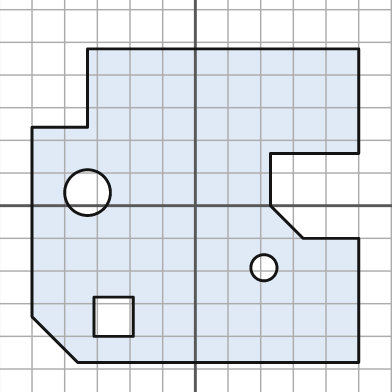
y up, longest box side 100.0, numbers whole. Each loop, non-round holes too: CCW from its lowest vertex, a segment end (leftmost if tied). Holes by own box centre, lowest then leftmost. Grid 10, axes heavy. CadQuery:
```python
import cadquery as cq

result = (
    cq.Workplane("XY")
    .moveTo(-36.0, -48.0)
    .lineTo(50.0, -48.0)
    .lineTo(50.0, -10.0)
    .lineTo(33.0, -10.0)
    .lineTo(23.0, 0.0)
    .lineTo(23.0, 16.0)
    .lineTo(50.0, 16.0)
    .lineTo(50.0, 48.0)
    .lineTo(-33.0, 48.0)
    .lineTo(-33.0, 24.0)
    .lineTo(-50.0, 24.0)
    .lineTo(-50.0, -34.0)
    .close()
    .moveTo(-31.0, -40.0)
    .lineTo(-19.0, -40.0)
    .lineTo(-19.0, -28.0)
    .lineTo(-31.0, -28.0)
    .close()
    .moveTo(21.0, -19.0)
    .circle(4.0)
    .moveTo(-33.0, 4.0)
    .circle(7.0)
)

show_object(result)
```